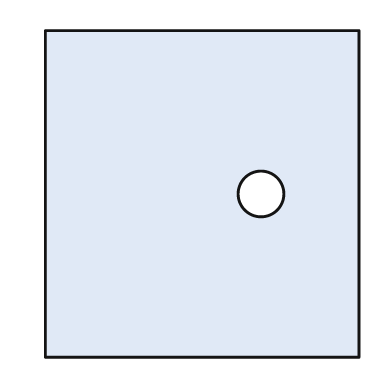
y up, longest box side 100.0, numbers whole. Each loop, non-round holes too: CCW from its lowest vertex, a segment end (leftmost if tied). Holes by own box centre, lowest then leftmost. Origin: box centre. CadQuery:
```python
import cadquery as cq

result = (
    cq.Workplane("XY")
    .moveTo(-48.0, -50.0)
    .lineTo(48.0, -50.0)
    .lineTo(48.0, 50.0)
    .lineTo(-48.0, 50.0)
    .close()
    .moveTo(18.0, 0.0)
    .circle(7.0)
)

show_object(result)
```